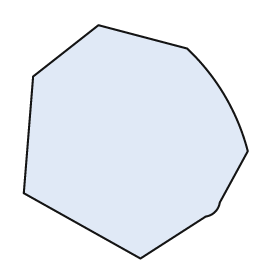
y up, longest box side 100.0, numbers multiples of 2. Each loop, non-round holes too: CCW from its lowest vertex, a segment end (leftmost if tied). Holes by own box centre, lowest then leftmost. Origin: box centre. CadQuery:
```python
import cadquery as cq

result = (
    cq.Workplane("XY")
    .moveTo(2.0, -50.0)
    .lineTo(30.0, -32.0)
    .threePointArc((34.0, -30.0), (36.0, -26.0))
    .lineTo(48.0, -4.0)
    .threePointArc((38.0, 20.0), (22.0, 40.0))
    .lineTo(-16.0, 50.0)
    .lineTo(-44.0, 28.0)
    .lineTo(-48.0, -22.0)
    .close()
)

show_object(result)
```